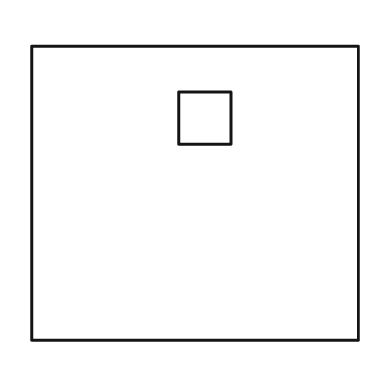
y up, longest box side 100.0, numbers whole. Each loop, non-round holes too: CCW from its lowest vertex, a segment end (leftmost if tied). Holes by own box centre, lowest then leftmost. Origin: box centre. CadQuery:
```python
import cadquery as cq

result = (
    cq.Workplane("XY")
    .moveTo(-50.0, -45.0)
    .lineTo(50.0, -45.0)
    .lineTo(50.0, 45.0)
    .lineTo(-50.0, 45.0)
    .close()
    .moveTo(-5.0, 15.0)
    .lineTo(11.0, 15.0)
    .lineTo(11.0, 31.0)
    .lineTo(-5.0, 31.0)
    .close()
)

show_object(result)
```